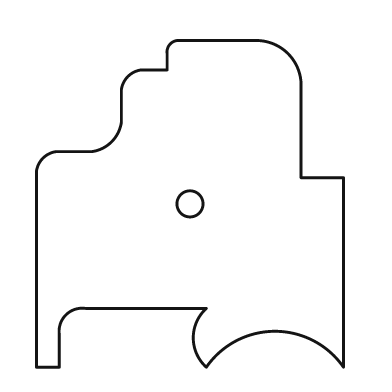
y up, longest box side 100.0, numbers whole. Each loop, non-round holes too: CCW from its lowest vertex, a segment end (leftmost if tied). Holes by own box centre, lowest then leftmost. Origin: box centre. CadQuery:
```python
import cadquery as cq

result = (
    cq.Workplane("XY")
    .moveTo(-47.0, -50.0)
    .lineTo(-40.0, -50.0)
    .lineTo(-40.0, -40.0)
    .threePointArc((-38.0, -34.0), (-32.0, -32.0))
    .lineTo(5.0, -32.0)
    .threePointArc((1.0, -41.0), (5.0, -50.0))
    .threePointArc((26.0, -39.0), (47.0, -50.0))
    .lineTo(47.0, 8.0)
    .lineTo(34.0, 8.0)
    .lineTo(34.0, 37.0)
    .threePointArc((30.0, 46.0), (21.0, 50.0))
    .lineTo(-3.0, 50.0)
    .threePointArc((-6.0, 49.0), (-7.0, 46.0))
    .lineTo(-7.0, 41.0)
    .lineTo(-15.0, 41.0)
    .threePointArc((-19.0, 39.0), (-21.0, 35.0))
    .lineTo(-21.0, 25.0)
    .threePointArc((-24.0, 19.0), (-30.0, 16.0))
    .lineTo(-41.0, 16.0)
    .threePointArc((-45.0, 14.0), (-47.0, 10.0))
    .close()
    .moveTo(0.0, 0.0)
    .circle(4.0)
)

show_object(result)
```